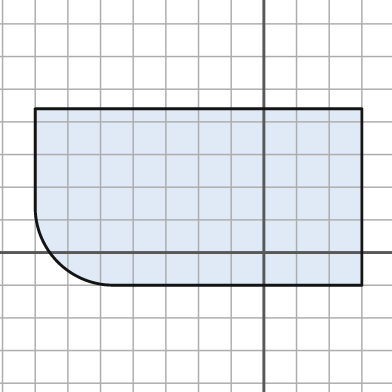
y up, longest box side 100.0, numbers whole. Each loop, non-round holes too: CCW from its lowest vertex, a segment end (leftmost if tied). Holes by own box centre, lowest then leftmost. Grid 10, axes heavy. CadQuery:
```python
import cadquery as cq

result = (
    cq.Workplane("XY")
    .moveTo(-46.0, -10.0)
    .lineTo(30.0, -10.0)
    .lineTo(30.0, 44.0)
    .lineTo(-70.0, 44.0)
    .lineTo(-70.0, 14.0)
    .threePointArc((-63.0, -3.0), (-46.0, -10.0))
    .close()
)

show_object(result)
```